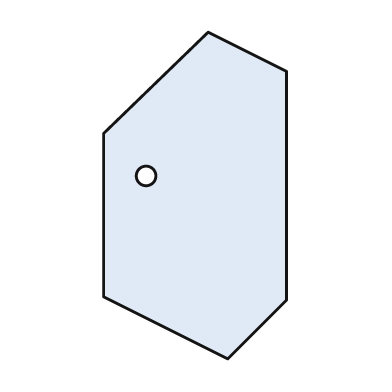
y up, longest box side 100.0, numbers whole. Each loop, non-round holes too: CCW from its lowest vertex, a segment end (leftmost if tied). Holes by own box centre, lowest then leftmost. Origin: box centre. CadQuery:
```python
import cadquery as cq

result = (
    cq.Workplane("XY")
    .moveTo(10.0, -50.0)
    .lineTo(28.0, -32.0)
    .lineTo(28.0, 38.0)
    .lineTo(4.0, 50.0)
    .lineTo(-28.0, 19.0)
    .lineTo(-28.0, -31.0)
    .close()
    .moveTo(-15.0, 6.0)
    .circle(3.0)
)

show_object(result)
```